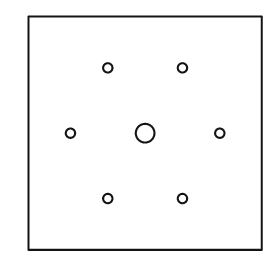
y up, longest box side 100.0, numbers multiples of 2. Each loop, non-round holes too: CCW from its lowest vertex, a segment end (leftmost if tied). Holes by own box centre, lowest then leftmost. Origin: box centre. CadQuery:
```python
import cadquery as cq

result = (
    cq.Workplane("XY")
    .moveTo(-50.0, -50.0)
    .lineTo(50.0, -50.0)
    .lineTo(50.0, 50.0)
    .lineTo(-50.0, 50.0)
    .close()
    .moveTo(-16.0, -28.0)
    .circle(2.0)
    .moveTo(16.0, -28.0)
    .circle(2.0)
    .moveTo(-32.0, 0.0)
    .circle(2.0)
    .moveTo(0.0, 0.0)
    .circle(4.0)
    .moveTo(32.0, 0.0)
    .circle(2.0)
    .moveTo(-16.0, 28.0)
    .circle(2.0)
    .moveTo(16.0, 28.0)
    .circle(2.0)
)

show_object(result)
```